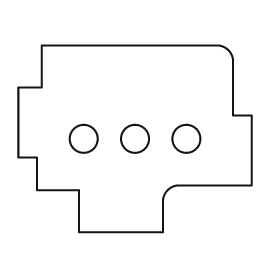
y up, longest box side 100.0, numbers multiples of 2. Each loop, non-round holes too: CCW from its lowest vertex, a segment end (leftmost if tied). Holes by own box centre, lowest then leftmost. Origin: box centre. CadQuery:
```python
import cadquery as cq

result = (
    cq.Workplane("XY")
    .moveTo(-24.0, -40.0)
    .lineTo(12.0, -40.0)
    .lineTo(12.0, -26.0)
    .threePointArc((14.0, -22.0), (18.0, -20.0))
    .lineTo(50.0, -20.0)
    .lineTo(50.0, 10.0)
    .lineTo(42.0, 10.0)
    .lineTo(42.0, 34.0)
    .threePointArc((40.0, 38.0), (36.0, 40.0))
    .lineTo(-40.0, 40.0)
    .lineTo(-40.0, 22.0)
    .lineTo(-50.0, 22.0)
    .lineTo(-50.0, -8.0)
    .lineTo(-42.0, -8.0)
    .lineTo(-42.0, -22.0)
    .lineTo(-24.0, -22.0)
    .close()
    .moveTo(-22.0, 0.0)
    .circle(6.0)
    .moveTo(0.0, 0.0)
    .circle(6.0)
    .moveTo(22.0, 0.0)
    .circle(6.0)
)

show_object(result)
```